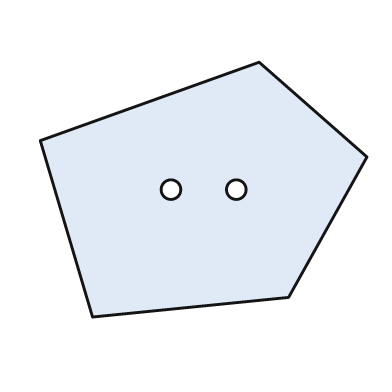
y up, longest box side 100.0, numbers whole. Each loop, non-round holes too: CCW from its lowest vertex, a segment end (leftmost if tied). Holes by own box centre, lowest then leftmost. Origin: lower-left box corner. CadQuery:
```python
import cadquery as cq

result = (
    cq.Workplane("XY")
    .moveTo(16.0, 0.0)
    .lineTo(76.0, 6.0)
    .lineTo(100.0, 49.0)
    .lineTo(67.0, 78.0)
    .lineTo(0.0, 54.0)
    .close()
    .moveTo(40.0, 39.0)
    .circle(3.0)
    .moveTo(60.0, 39.0)
    .circle(3.0)
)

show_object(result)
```